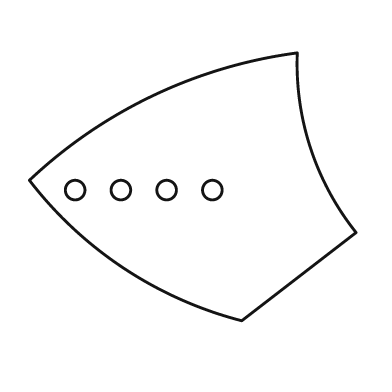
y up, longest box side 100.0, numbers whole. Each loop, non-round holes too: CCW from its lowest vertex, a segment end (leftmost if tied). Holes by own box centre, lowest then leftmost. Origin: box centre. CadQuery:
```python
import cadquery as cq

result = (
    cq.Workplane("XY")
    .moveTo(15.0, -41.0)
    .lineTo(50.0, -14.0)
    .threePointArc((36.0, 12.0), (32.0, 41.0))
    .threePointArc((-12.0, 28.0), (-50.0, 2.0))
    .threePointArc((-21.0, -25.0), (15.0, -41.0))
    .close()
    .moveTo(-36.0, -1.0)
    .circle(3.0)
    .moveTo(-22.0, -1.0)
    .circle(3.0)
    .moveTo(-8.0, -1.0)
    .circle(3.0)
    .moveTo(6.0, -1.0)
    .circle(3.0)
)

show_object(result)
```